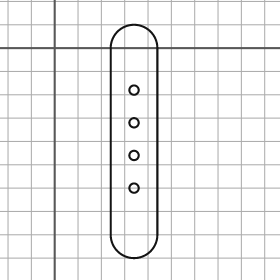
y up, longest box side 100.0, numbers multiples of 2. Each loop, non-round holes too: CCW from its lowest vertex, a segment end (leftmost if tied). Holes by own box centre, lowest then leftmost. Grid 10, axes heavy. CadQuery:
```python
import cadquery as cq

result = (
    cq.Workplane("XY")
    .moveTo(24.0, -80.0)
    .threePointArc((34.0, -90.0), (44.0, -80.0))
    .lineTo(44.0, 0.0)
    .threePointArc((34.0, 10.0), (24.0, 0.0))
    .close()
    .moveTo(34.0, -60.0)
    .circle(2.0)
    .moveTo(34.0, -46.0)
    .circle(2.0)
    .moveTo(34.0, -32.0)
    .circle(2.0)
    .moveTo(34.0, -18.0)
    .circle(2.0)
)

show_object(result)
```